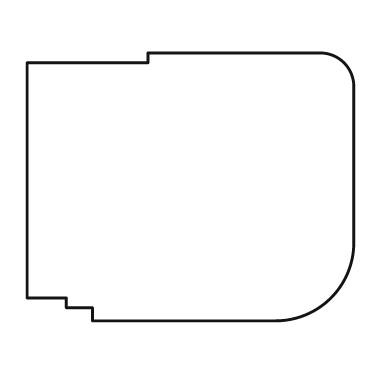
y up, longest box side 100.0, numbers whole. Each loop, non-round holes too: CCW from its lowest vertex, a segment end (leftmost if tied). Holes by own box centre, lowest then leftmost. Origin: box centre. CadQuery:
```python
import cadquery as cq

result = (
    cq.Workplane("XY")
    .moveTo(-30.0, -41.0)
    .lineTo(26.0, -41.0)
    .threePointArc((43.0, -34.0), (50.0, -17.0))
    .lineTo(50.0, 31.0)
    .threePointArc((47.0, 38.0), (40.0, 41.0))
    .lineTo(-13.0, 41.0)
    .lineTo(-13.0, 38.0)
    .lineTo(-50.0, 38.0)
    .lineTo(-50.0, -34.0)
    .lineTo(-38.0, -34.0)
    .lineTo(-38.0, -37.0)
    .lineTo(-30.0, -37.0)
    .close()
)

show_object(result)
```